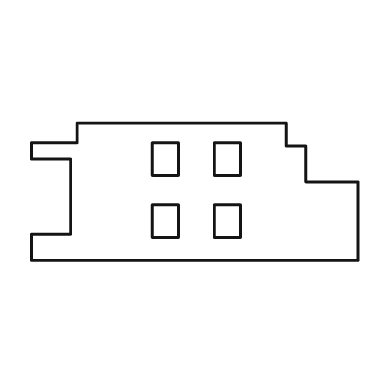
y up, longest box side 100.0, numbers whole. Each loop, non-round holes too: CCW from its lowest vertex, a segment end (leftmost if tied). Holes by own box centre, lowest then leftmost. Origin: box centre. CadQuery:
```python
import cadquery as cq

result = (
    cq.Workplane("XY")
    .moveTo(-50.0, -21.0)
    .lineTo(50.0, -21.0)
    .lineTo(50.0, 3.0)
    .lineTo(34.0, 3.0)
    .lineTo(34.0, 14.0)
    .lineTo(28.0, 14.0)
    .lineTo(28.0, 21.0)
    .lineTo(-36.0, 21.0)
    .lineTo(-36.0, 15.0)
    .lineTo(-50.0, 15.0)
    .lineTo(-50.0, 10.0)
    .lineTo(-38.0, 10.0)
    .lineTo(-38.0, -13.0)
    .lineTo(-50.0, -13.0)
    .close()
    .moveTo(-13.0, -14.0)
    .lineTo(-5.0, -14.0)
    .lineTo(-5.0, -4.0)
    .lineTo(-13.0, -4.0)
    .close()
    .moveTo(6.0, -14.0)
    .lineTo(14.0, -14.0)
    .lineTo(14.0, -4.0)
    .lineTo(6.0, -4.0)
    .close()
    .moveTo(-13.0, 5.0)
    .lineTo(-5.0, 5.0)
    .lineTo(-5.0, 15.0)
    .lineTo(-13.0, 15.0)
    .close()
    .moveTo(6.0, 5.0)
    .lineTo(14.0, 5.0)
    .lineTo(14.0, 15.0)
    .lineTo(6.0, 15.0)
    .close()
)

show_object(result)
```